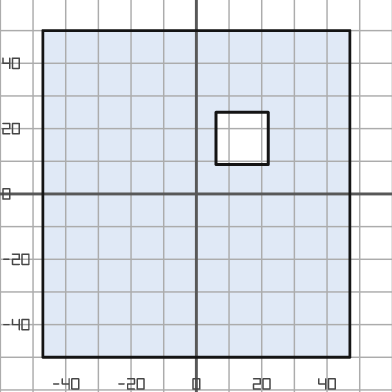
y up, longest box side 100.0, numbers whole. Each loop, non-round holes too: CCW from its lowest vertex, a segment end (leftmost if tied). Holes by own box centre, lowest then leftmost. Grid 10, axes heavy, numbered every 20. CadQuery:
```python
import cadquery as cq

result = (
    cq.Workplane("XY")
    .moveTo(-47.0, -50.0)
    .lineTo(47.0, -50.0)
    .lineTo(47.0, 50.0)
    .lineTo(-47.0, 50.0)
    .close()
    .moveTo(6.0, 9.0)
    .lineTo(22.0, 9.0)
    .lineTo(22.0, 25.0)
    .lineTo(6.0, 25.0)
    .close()
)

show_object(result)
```